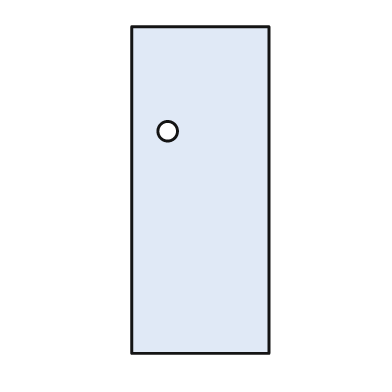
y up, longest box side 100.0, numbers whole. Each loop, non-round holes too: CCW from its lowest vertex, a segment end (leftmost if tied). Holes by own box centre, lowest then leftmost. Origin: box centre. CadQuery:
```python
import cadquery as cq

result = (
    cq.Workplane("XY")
    .moveTo(-21.0, -50.0)
    .lineTo(21.0, -50.0)
    .lineTo(21.0, 50.0)
    .lineTo(-21.0, 50.0)
    .close()
    .moveTo(-10.0, 18.0)
    .circle(3.0)
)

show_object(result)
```